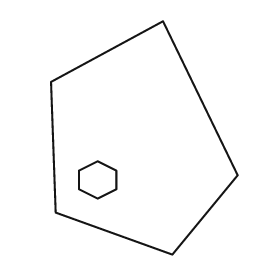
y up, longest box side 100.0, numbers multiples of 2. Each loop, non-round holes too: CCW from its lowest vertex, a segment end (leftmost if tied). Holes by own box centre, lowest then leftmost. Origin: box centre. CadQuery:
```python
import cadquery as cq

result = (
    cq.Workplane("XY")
    .moveTo(12.0, -50.0)
    .lineTo(40.0, -16.0)
    .lineTo(8.0, 50.0)
    .lineTo(-40.0, 24.0)
    .lineTo(-38.0, -32.0)
    .close()
    .moveTo(-20.0, -26.0)
    .lineTo(-12.0, -22.0)
    .lineTo(-12.0, -14.0)
    .lineTo(-20.0, -10.0)
    .lineTo(-28.0, -14.0)
    .lineTo(-28.0, -22.0)
    .close()
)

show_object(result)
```